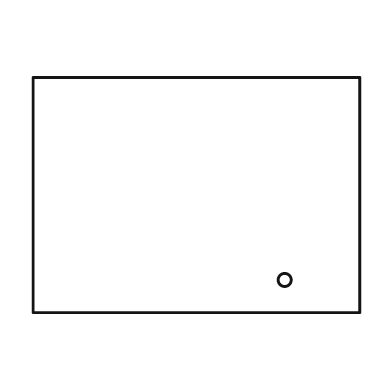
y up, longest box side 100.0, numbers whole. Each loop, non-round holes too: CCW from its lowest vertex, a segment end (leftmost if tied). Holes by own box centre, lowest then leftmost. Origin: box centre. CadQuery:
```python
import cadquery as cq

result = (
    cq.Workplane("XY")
    .moveTo(-50.0, -36.0)
    .lineTo(50.0, -36.0)
    .lineTo(50.0, 36.0)
    .lineTo(-50.0, 36.0)
    .close()
    .moveTo(27.0, -26.0)
    .circle(2.0)
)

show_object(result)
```